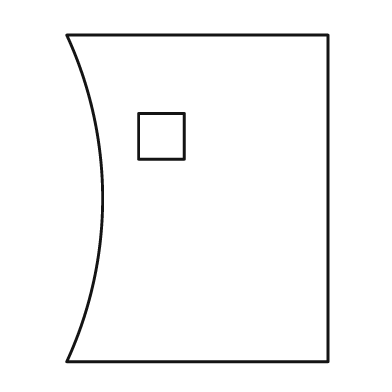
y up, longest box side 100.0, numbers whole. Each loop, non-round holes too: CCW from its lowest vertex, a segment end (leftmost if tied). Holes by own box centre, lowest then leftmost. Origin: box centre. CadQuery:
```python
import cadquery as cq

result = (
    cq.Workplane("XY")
    .moveTo(-40.0, -50.0)
    .lineTo(40.0, -50.0)
    .lineTo(40.0, 50.0)
    .lineTo(-40.0, 50.0)
    .threePointArc((-29.0, 0.0), (-40.0, -50.0))
    .close()
    .moveTo(-18.0, 12.0)
    .lineTo(-4.0, 12.0)
    .lineTo(-4.0, 26.0)
    .lineTo(-18.0, 26.0)
    .close()
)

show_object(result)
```